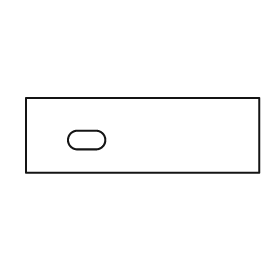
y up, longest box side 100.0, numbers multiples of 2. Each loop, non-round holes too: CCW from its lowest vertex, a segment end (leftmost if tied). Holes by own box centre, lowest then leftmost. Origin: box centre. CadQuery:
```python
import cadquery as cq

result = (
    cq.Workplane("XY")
    .moveTo(-50.0, -16.0)
    .lineTo(50.0, -16.0)
    .lineTo(50.0, 16.0)
    .lineTo(-50.0, 16.0)
    .close()
    .moveTo(-28.0, -6.0)
    .lineTo(-20.0, -6.0)
    .threePointArc((-16.0, -2.0), (-20.0, 2.0))
    .lineTo(-28.0, 2.0)
    .threePointArc((-32.0, -2.0), (-28.0, -6.0))
    .close()
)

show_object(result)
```